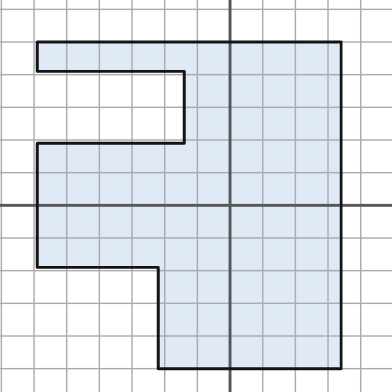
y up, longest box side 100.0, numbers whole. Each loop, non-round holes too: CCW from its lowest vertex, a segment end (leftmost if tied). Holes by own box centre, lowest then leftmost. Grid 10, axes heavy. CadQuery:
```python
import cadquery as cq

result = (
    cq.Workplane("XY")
    .moveTo(-22.0, -50.0)
    .lineTo(34.0, -50.0)
    .lineTo(34.0, 50.0)
    .lineTo(-59.0, 50.0)
    .lineTo(-59.0, 41.0)
    .lineTo(-14.0, 41.0)
    .lineTo(-14.0, 19.0)
    .lineTo(-59.0, 19.0)
    .lineTo(-59.0, -19.0)
    .lineTo(-22.0, -19.0)
    .close()
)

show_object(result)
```